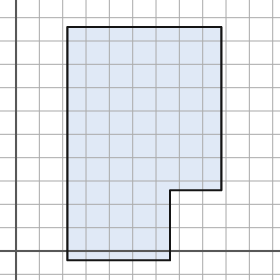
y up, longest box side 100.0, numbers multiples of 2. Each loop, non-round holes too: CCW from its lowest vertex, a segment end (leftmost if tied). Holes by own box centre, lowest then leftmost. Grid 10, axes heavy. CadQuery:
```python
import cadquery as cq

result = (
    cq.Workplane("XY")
    .moveTo(22.0, -4.0)
    .lineTo(66.0, -4.0)
    .lineTo(66.0, 26.0)
    .lineTo(88.0, 26.0)
    .lineTo(88.0, 96.0)
    .lineTo(22.0, 96.0)
    .close()
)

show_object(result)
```